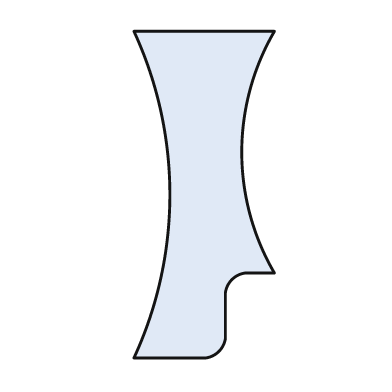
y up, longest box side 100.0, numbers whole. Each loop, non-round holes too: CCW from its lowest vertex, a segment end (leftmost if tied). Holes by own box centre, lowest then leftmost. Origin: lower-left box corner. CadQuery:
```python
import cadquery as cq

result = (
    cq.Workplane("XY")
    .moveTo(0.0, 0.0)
    .lineTo(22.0, 0.0)
    .threePointArc((26.0, 2.0), (28.0, 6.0))
    .lineTo(28.0, 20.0)
    .threePointArc((30.0, 24.0), (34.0, 26.0))
    .lineTo(43.0, 26.0)
    .threePointArc((33.0, 63.0), (43.0, 100.0))
    .lineTo(0.0, 100.0)
    .threePointArc((11.0, 50.0), (0.0, 0.0))
    .close()
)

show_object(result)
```